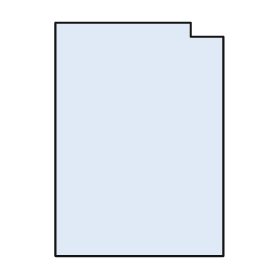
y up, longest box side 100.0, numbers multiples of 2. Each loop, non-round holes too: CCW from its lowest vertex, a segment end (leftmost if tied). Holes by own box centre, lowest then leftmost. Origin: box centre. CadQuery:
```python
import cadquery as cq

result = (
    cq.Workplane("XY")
    .moveTo(-36.0, -50.0)
    .lineTo(36.0, -50.0)
    .lineTo(36.0, 44.0)
    .lineTo(22.0, 44.0)
    .lineTo(22.0, 50.0)
    .lineTo(-36.0, 50.0)
    .close()
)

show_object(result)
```